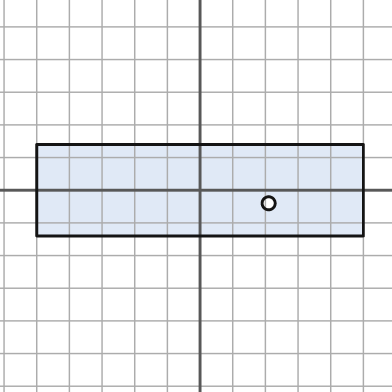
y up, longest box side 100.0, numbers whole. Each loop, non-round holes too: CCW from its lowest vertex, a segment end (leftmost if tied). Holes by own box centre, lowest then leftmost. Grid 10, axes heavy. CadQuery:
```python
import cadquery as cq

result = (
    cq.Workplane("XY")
    .moveTo(-50.0, -14.0)
    .lineTo(50.0, -14.0)
    .lineTo(50.0, 14.0)
    .lineTo(-50.0, 14.0)
    .close()
    .moveTo(21.0, -4.0)
    .circle(2.0)
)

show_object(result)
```